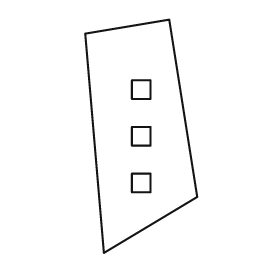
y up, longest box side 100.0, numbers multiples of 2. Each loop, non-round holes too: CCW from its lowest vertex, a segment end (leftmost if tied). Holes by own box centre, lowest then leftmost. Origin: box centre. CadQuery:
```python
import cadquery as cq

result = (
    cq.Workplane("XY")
    .moveTo(-16.0, -50.0)
    .lineTo(24.0, -26.0)
    .lineTo(12.0, 50.0)
    .lineTo(-24.0, 44.0)
    .close()
    .moveTo(-4.0, -24.0)
    .lineTo(4.0, -24.0)
    .lineTo(4.0, -16.0)
    .lineTo(-4.0, -16.0)
    .close()
    .moveTo(-4.0, -4.0)
    .lineTo(4.0, -4.0)
    .lineTo(4.0, 4.0)
    .lineTo(-4.0, 4.0)
    .close()
    .moveTo(-4.0, 16.0)
    .lineTo(4.0, 16.0)
    .lineTo(4.0, 24.0)
    .lineTo(-4.0, 24.0)
    .close()
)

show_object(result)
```